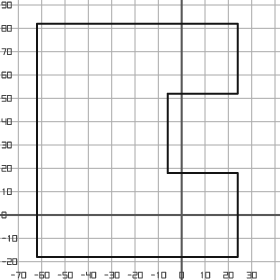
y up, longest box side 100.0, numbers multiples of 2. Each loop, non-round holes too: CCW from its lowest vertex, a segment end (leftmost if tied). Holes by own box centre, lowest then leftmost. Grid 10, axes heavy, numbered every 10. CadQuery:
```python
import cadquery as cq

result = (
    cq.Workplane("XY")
    .moveTo(-62.0, -18.0)
    .lineTo(24.0, -18.0)
    .lineTo(24.0, 18.0)
    .lineTo(-6.0, 18.0)
    .lineTo(-6.0, 52.0)
    .lineTo(24.0, 52.0)
    .lineTo(24.0, 82.0)
    .lineTo(-62.0, 82.0)
    .close()
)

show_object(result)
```